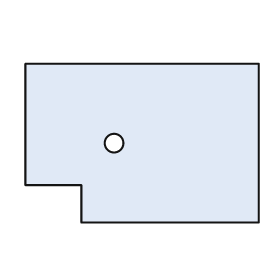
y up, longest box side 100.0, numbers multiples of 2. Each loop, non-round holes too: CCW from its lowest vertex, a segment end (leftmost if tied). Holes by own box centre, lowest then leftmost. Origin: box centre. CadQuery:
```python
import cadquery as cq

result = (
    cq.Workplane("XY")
    .moveTo(-26.0, -34.0)
    .lineTo(50.0, -34.0)
    .lineTo(50.0, 34.0)
    .lineTo(-50.0, 34.0)
    .lineTo(-50.0, -18.0)
    .lineTo(-26.0, -18.0)
    .close()
    .moveTo(-12.0, 0.0)
    .circle(4.0)
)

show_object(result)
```